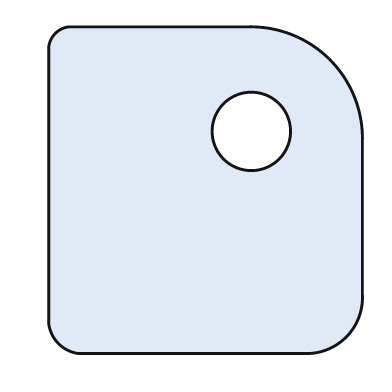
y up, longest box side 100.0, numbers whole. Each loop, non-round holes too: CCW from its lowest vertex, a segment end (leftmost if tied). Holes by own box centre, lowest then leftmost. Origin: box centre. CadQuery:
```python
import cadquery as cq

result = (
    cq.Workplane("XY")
    .moveTo(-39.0, -50.0)
    .lineTo(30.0, -50.0)
    .threePointArc((43.0, -45.0), (48.0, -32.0))
    .lineTo(48.0, 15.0)
    .threePointArc((38.0, 40.0), (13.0, 50.0))
    .lineTo(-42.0, 50.0)
    .threePointArc((-46.0, 48.0), (-48.0, 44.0))
    .lineTo(-48.0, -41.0)
    .threePointArc((-45.0, -47.0), (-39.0, -50.0))
    .close()
    .moveTo(14.0, 18.0)
    .circle(12.0)
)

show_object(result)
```